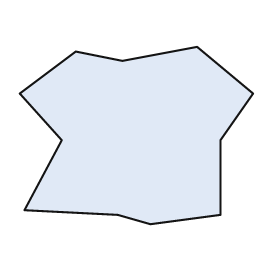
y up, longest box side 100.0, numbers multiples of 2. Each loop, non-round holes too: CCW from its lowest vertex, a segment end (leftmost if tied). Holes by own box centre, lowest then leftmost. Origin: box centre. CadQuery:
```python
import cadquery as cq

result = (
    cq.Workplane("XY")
    .moveTo(6.0, -38.0)
    .lineTo(36.0, -34.0)
    .lineTo(36.0, -2.0)
    .lineTo(50.0, 18.0)
    .lineTo(26.0, 38.0)
    .lineTo(-6.0, 32.0)
    .lineTo(-26.0, 36.0)
    .lineTo(-50.0, 18.0)
    .lineTo(-32.0, -2.0)
    .lineTo(-48.0, -32.0)
    .lineTo(-8.0, -34.0)
    .close()
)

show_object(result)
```